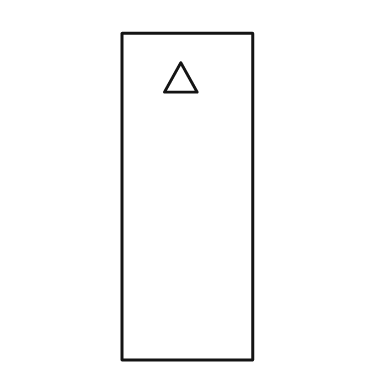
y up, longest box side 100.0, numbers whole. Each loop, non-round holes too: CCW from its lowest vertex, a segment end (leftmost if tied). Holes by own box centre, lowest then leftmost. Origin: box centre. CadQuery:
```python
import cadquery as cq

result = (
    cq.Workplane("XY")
    .moveTo(-20.0, -50.0)
    .lineTo(20.0, -50.0)
    .lineTo(20.0, 50.0)
    .lineTo(-20.0, 50.0)
    .close()
    .moveTo(-7.0, 32.0)
    .lineTo(3.0, 32.0)
    .lineTo(-2.0, 41.0)
    .close()
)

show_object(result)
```